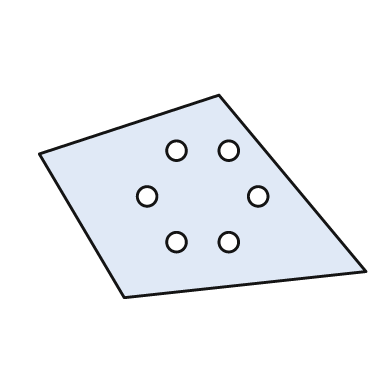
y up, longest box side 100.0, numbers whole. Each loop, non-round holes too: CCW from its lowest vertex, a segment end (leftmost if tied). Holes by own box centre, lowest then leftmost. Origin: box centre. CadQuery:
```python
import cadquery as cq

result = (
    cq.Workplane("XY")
    .moveTo(-24.0, -31.0)
    .lineTo(50.0, -23.0)
    .lineTo(5.0, 31.0)
    .lineTo(-50.0, 13.0)
    .close()
    .moveTo(-8.0, -14.0)
    .circle(3.0)
    .moveTo(8.0, -14.0)
    .circle(3.0)
    .moveTo(-17.0, 0.0)
    .circle(3.0)
    .moveTo(17.0, 0.0)
    .circle(3.0)
    .moveTo(-8.0, 14.0)
    .circle(3.0)
    .moveTo(8.0, 14.0)
    .circle(3.0)
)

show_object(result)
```